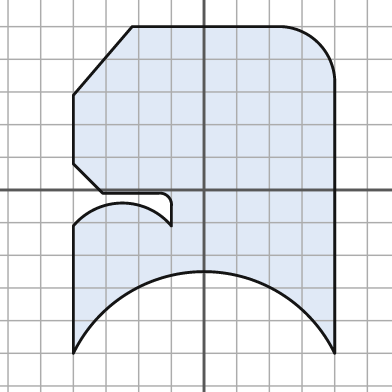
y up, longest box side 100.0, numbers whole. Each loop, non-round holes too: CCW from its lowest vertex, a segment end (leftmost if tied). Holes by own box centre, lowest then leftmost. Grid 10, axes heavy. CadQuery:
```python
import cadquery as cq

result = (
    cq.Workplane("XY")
    .moveTo(-40.0, -50.0)
    .threePointArc((0.0, -25.0), (40.0, -50.0))
    .lineTo(40.0, 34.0)
    .threePointArc((35.0, 45.0), (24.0, 50.0))
    .lineTo(-22.0, 50.0)
    .lineTo(-40.0, 29.0)
    .lineTo(-40.0, 8.0)
    .lineTo(-31.0, -1.0)
    .lineTo(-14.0, -1.0)
    .threePointArc((-11.0, -2.0), (-10.0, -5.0))
    .lineTo(-10.0, -11.0)
    .threePointArc((-25.0, -4.0), (-40.0, -11.0))
    .close()
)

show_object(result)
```